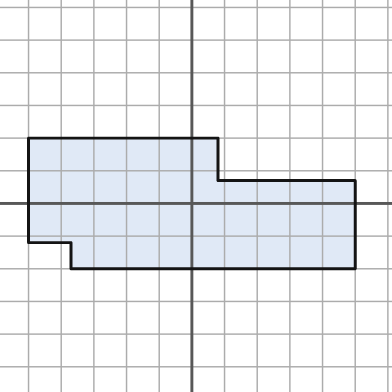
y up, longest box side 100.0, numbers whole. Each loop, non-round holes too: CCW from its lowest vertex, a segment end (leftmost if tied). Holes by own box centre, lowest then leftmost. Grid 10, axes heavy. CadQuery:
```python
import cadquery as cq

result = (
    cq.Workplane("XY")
    .moveTo(-37.0, -20.0)
    .lineTo(50.0, -20.0)
    .lineTo(50.0, 7.0)
    .lineTo(8.0, 7.0)
    .lineTo(8.0, 20.0)
    .lineTo(-50.0, 20.0)
    .lineTo(-50.0, -12.0)
    .lineTo(-37.0, -12.0)
    .close()
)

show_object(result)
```